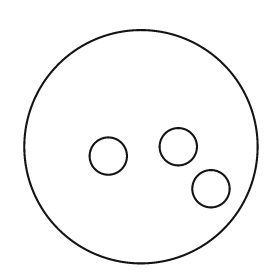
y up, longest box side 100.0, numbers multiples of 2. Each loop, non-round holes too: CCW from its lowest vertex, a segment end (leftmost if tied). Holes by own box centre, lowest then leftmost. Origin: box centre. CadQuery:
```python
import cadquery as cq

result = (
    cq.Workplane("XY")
    .moveTo(0.0, 0.0)
    .circle(50.0)
    .moveTo(30.0, -18.0)
    .circle(8.0)
    .moveTo(-14.0, -4.0)
    .circle(8.0)
    .moveTo(16.0, 0.0)
    .circle(8.0)
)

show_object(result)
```